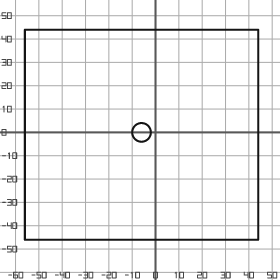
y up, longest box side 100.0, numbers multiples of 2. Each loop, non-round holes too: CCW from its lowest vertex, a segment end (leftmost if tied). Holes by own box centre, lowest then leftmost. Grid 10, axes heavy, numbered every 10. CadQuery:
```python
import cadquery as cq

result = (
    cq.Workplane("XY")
    .moveTo(-56.0, -46.0)
    .lineTo(44.0, -46.0)
    .lineTo(44.0, 44.0)
    .lineTo(-56.0, 44.0)
    .close()
    .moveTo(-6.0, 0.0)
    .circle(4.0)
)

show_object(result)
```